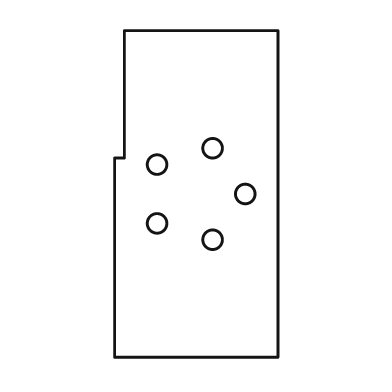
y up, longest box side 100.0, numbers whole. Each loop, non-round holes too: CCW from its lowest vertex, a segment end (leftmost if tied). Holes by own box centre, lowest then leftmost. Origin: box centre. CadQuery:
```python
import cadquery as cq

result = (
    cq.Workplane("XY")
    .moveTo(-25.0, -50.0)
    .lineTo(25.0, -50.0)
    .lineTo(25.0, 50.0)
    .lineTo(-22.0, 50.0)
    .lineTo(-22.0, 11.0)
    .lineTo(-25.0, 11.0)
    .close()
    .moveTo(5.0, -14.0)
    .circle(3.0)
    .moveTo(-12.0, -9.0)
    .circle(3.0)
    .moveTo(15.0, 0.0)
    .circle(3.0)
    .moveTo(-12.0, 9.0)
    .circle(3.0)
    .moveTo(5.0, 14.0)
    .circle(3.0)
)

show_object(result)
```